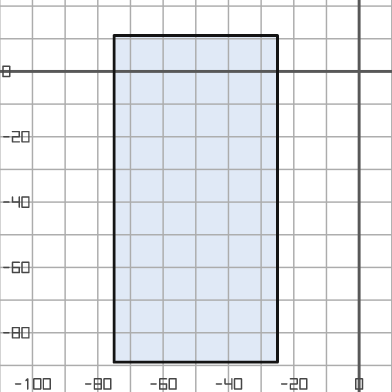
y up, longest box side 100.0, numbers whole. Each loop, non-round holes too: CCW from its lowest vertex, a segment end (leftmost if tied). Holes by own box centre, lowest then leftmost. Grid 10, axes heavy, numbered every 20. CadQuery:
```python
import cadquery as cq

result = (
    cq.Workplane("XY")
    .moveTo(-75.0, -89.0)
    .lineTo(-25.0, -89.0)
    .lineTo(-25.0, 11.0)
    .lineTo(-75.0, 11.0)
    .close()
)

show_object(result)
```